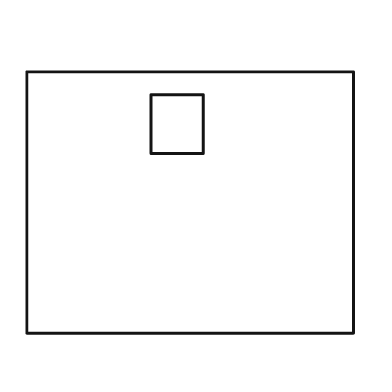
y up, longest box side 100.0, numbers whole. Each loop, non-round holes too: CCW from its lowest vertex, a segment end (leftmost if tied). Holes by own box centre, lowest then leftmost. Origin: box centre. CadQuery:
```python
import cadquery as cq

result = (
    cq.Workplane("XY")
    .moveTo(-50.0, -40.0)
    .lineTo(50.0, -40.0)
    .lineTo(50.0, 40.0)
    .lineTo(-50.0, 40.0)
    .close()
    .moveTo(-12.0, 15.0)
    .lineTo(4.0, 15.0)
    .lineTo(4.0, 33.0)
    .lineTo(-12.0, 33.0)
    .close()
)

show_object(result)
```